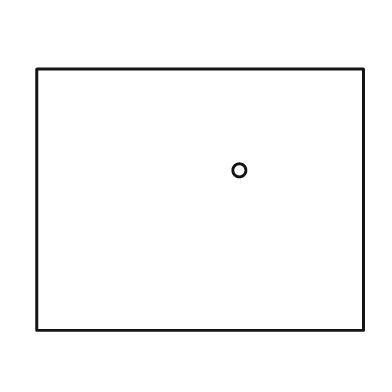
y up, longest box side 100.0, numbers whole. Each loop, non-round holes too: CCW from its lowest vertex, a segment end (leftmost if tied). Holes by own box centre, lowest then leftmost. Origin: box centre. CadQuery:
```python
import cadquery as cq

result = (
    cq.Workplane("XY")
    .moveTo(-50.0, -40.0)
    .lineTo(50.0, -40.0)
    .lineTo(50.0, 40.0)
    .lineTo(-50.0, 40.0)
    .close()
    .moveTo(12.0, 9.0)
    .circle(2.0)
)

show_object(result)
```